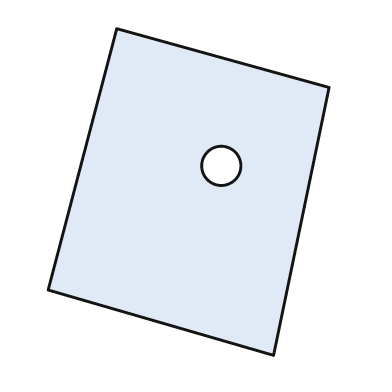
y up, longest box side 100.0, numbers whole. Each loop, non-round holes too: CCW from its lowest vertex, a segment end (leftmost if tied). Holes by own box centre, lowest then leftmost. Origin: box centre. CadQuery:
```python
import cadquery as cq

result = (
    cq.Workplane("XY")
    .moveTo(26.0, -50.0)
    .lineTo(43.0, 32.0)
    .lineTo(-22.0, 50.0)
    .lineTo(-43.0, -30.0)
    .close()
    .moveTo(10.0, 8.0)
    .circle(6.0)
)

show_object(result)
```